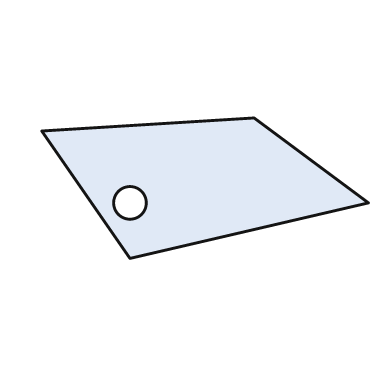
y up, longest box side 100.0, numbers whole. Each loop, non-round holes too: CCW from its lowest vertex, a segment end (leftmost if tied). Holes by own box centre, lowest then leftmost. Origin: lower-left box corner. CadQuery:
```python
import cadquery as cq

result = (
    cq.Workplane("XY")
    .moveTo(27.0, 0.0)
    .lineTo(100.0, 17.0)
    .lineTo(65.0, 43.0)
    .lineTo(0.0, 39.0)
    .close()
    .moveTo(27.0, 17.0)
    .circle(5.0)
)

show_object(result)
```